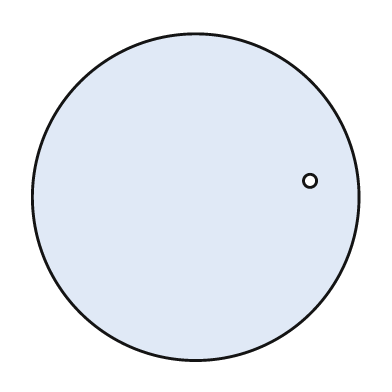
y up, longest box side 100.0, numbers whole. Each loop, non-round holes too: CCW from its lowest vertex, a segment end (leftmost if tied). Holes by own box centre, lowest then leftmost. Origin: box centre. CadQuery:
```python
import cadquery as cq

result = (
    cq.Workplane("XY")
    .moveTo(0.0, 0.0)
    .circle(50.0)
    .moveTo(35.0, 5.0)
    .circle(2.0)
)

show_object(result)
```